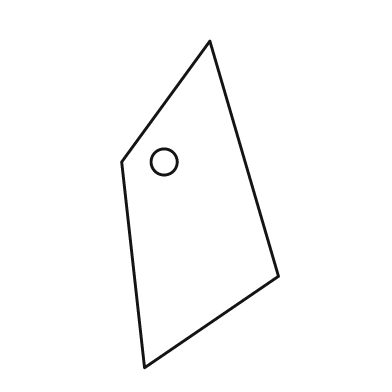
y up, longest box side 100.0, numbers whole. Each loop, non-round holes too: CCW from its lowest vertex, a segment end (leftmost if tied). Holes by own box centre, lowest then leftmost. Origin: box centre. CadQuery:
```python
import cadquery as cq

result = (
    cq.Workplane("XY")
    .moveTo(-17.0, -50.0)
    .lineTo(24.0, -22.0)
    .lineTo(3.0, 50.0)
    .lineTo(-24.0, 13.0)
    .close()
    .moveTo(-11.0, 13.0)
    .circle(4.0)
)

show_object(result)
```